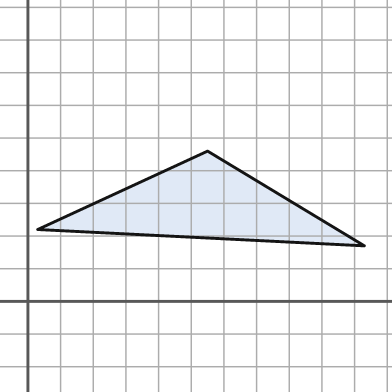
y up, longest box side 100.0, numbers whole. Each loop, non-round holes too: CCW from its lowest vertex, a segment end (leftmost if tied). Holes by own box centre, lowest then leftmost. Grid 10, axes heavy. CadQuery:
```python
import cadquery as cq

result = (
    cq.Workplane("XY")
    .moveTo(103.0, 17.0)
    .lineTo(55.0, 46.0)
    .lineTo(3.0, 22.0)
    .close()
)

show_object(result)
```